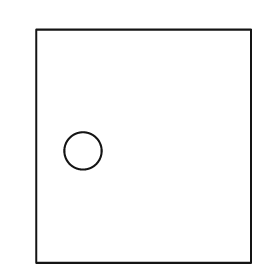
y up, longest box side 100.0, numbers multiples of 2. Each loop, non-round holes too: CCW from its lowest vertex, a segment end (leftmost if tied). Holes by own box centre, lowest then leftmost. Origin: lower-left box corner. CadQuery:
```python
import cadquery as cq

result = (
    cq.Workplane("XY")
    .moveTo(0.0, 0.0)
    .lineTo(92.0, 0.0)
    .lineTo(92.0, 100.0)
    .lineTo(0.0, 100.0)
    .close()
    .moveTo(20.0, 48.0)
    .circle(8.0)
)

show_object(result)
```